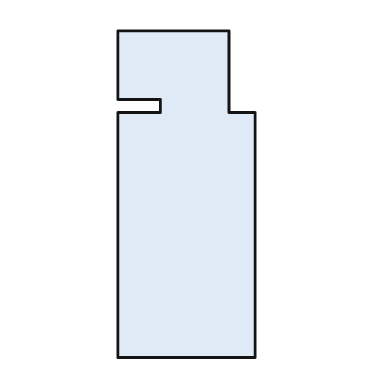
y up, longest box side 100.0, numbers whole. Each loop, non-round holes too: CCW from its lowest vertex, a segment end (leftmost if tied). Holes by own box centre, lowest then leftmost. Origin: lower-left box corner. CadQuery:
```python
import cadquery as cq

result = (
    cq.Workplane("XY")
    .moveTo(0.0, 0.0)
    .lineTo(42.0, 0.0)
    .lineTo(42.0, 75.0)
    .lineTo(34.0, 75.0)
    .lineTo(34.0, 100.0)
    .lineTo(0.0, 100.0)
    .lineTo(0.0, 79.0)
    .lineTo(13.0, 79.0)
    .lineTo(13.0, 75.0)
    .lineTo(0.0, 75.0)
    .close()
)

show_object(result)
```